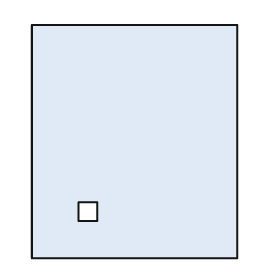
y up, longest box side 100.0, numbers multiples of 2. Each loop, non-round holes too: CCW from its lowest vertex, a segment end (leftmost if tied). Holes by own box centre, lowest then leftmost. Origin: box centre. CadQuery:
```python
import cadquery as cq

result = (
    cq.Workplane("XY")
    .moveTo(-44.0, -50.0)
    .lineTo(44.0, -50.0)
    .lineTo(44.0, 50.0)
    .lineTo(-44.0, 50.0)
    .close()
    .moveTo(-24.0, -34.0)
    .lineTo(-16.0, -34.0)
    .lineTo(-16.0, -26.0)
    .lineTo(-24.0, -26.0)
    .close()
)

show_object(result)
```